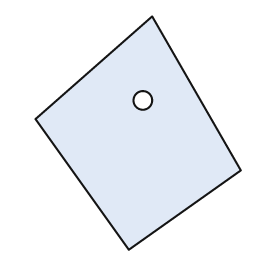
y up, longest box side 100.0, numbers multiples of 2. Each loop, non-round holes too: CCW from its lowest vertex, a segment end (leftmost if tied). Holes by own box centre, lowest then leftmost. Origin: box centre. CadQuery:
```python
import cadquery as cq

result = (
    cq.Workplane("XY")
    .moveTo(-4.0, -50.0)
    .lineTo(44.0, -16.0)
    .lineTo(6.0, 50.0)
    .lineTo(-44.0, 6.0)
    .close()
    .moveTo(2.0, 14.0)
    .circle(4.0)
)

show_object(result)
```